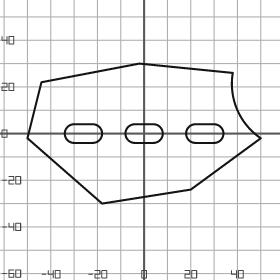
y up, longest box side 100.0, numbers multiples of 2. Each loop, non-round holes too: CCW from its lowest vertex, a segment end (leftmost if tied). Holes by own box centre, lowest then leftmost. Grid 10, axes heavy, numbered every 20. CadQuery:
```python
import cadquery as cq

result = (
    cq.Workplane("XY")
    .moveTo(-18.0, -30.0)
    .lineTo(20.0, -24.0)
    .lineTo(50.0, -2.0)
    .threePointArc((40.0, 10.0), (38.0, 26.0))
    .lineTo(-2.0, 30.0)
    .lineTo(-44.0, 22.0)
    .lineTo(-50.0, -2.0)
    .close()
    .moveTo(-30.0, -4.0)
    .lineTo(-22.0, -4.0)
    .threePointArc((-18.0, 0.0), (-22.0, 4.0))
    .lineTo(-30.0, 4.0)
    .threePointArc((-34.0, 0.0), (-30.0, -4.0))
    .close()
    .moveTo(-4.0, -4.0)
    .lineTo(4.0, -4.0)
    .threePointArc((8.0, 0.0), (4.0, 4.0))
    .lineTo(-4.0, 4.0)
    .threePointArc((-8.0, 0.0), (-4.0, -4.0))
    .close()
    .moveTo(22.0, -4.0)
    .lineTo(30.0, -4.0)
    .threePointArc((34.0, 0.0), (30.0, 4.0))
    .lineTo(22.0, 4.0)
    .threePointArc((18.0, 0.0), (22.0, -4.0))
    .close()
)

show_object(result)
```